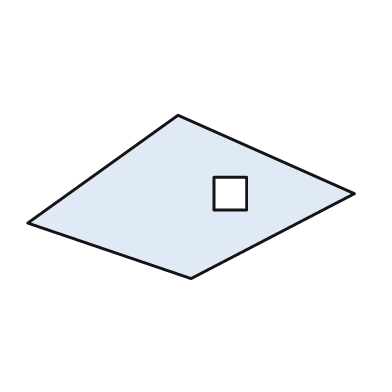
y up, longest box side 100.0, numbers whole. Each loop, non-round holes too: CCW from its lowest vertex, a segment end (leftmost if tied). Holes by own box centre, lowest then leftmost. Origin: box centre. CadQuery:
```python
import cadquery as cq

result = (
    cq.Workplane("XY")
    .moveTo(0.0, -25.0)
    .lineTo(50.0, 1.0)
    .lineTo(-4.0, 25.0)
    .lineTo(-50.0, -8.0)
    .close()
    .moveTo(7.0, -4.0)
    .lineTo(17.0, -4.0)
    .lineTo(17.0, 6.0)
    .lineTo(7.0, 6.0)
    .close()
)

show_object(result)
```